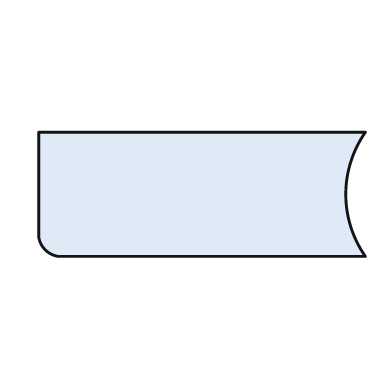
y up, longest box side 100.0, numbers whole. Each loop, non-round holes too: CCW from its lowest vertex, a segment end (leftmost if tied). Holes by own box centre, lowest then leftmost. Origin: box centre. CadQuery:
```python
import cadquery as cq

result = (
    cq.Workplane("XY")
    .moveTo(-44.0, -19.0)
    .lineTo(50.0, -19.0)
    .threePointArc((44.0, 0.0), (50.0, 19.0))
    .lineTo(-50.0, 19.0)
    .lineTo(-50.0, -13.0)
    .threePointArc((-48.0, -17.0), (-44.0, -19.0))
    .close()
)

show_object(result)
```